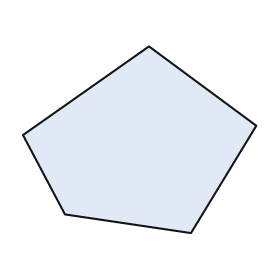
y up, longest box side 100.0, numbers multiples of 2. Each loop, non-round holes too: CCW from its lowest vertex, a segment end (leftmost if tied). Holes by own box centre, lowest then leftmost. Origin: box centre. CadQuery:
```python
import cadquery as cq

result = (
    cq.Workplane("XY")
    .moveTo(22.0, -40.0)
    .lineTo(50.0, 6.0)
    .lineTo(4.0, 40.0)
    .lineTo(-50.0, 2.0)
    .lineTo(-32.0, -32.0)
    .close()
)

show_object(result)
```